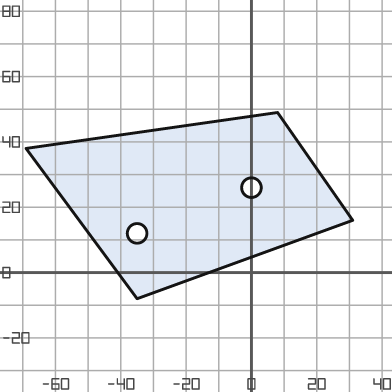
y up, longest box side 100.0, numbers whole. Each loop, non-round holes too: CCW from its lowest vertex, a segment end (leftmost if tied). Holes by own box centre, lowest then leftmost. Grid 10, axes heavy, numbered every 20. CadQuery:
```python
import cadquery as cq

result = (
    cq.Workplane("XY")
    .moveTo(-35.0, -8.0)
    .lineTo(31.0, 16.0)
    .lineTo(8.0, 49.0)
    .lineTo(-69.0, 38.0)
    .close()
    .moveTo(-35.0, 12.0)
    .circle(3.0)
    .moveTo(0.0, 26.0)
    .circle(3.0)
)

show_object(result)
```